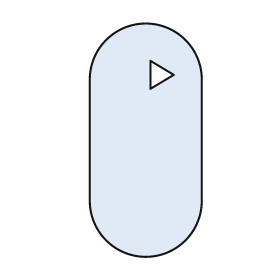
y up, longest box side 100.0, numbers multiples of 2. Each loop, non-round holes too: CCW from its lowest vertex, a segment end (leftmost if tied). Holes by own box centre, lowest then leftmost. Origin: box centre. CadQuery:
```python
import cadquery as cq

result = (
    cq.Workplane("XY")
    .moveTo(-24.0, -26.0)
    .threePointArc((0.0, -50.0), (24.0, -26.0))
    .lineTo(24.0, 26.0)
    .threePointArc((0.0, 50.0), (-24.0, 26.0))
    .close()
    .moveTo(2.0, 22.0)
    .lineTo(12.0, 28.0)
    .lineTo(2.0, 34.0)
    .close()
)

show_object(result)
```